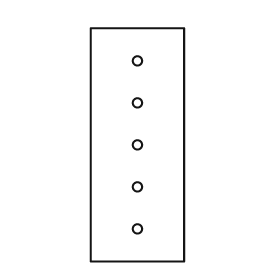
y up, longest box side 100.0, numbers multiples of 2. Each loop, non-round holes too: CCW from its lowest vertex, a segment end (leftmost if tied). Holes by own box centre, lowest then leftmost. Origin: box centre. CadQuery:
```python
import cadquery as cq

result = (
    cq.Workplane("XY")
    .moveTo(-20.0, -50.0)
    .lineTo(20.0, -50.0)
    .lineTo(20.0, 50.0)
    .lineTo(-20.0, 50.0)
    .close()
    .moveTo(0.0, -36.0)
    .circle(2.0)
    .moveTo(0.0, -18.0)
    .circle(2.0)
    .moveTo(0.0, 0.0)
    .circle(2.0)
    .moveTo(0.0, 18.0)
    .circle(2.0)
    .moveTo(0.0, 36.0)
    .circle(2.0)
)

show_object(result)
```